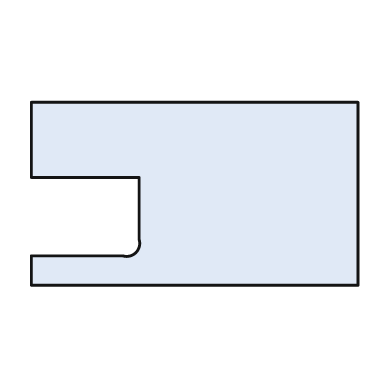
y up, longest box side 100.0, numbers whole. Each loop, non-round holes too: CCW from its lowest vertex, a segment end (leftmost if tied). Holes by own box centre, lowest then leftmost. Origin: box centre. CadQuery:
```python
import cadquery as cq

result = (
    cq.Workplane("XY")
    .moveTo(-50.0, -28.0)
    .lineTo(50.0, -28.0)
    .lineTo(50.0, 28.0)
    .lineTo(-50.0, 28.0)
    .lineTo(-50.0, 5.0)
    .lineTo(-17.0, 5.0)
    .lineTo(-17.0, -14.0)
    .threePointArc((-18.0, -18.0), (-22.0, -19.0))
    .lineTo(-50.0, -19.0)
    .close()
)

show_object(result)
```